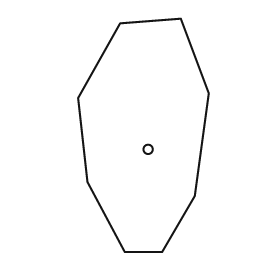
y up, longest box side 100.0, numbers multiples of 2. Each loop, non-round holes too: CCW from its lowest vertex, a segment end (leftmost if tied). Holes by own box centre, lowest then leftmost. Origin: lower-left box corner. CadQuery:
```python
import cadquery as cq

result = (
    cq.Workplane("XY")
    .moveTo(20.0, 0.0)
    .lineTo(36.0, 0.0)
    .lineTo(50.0, 24.0)
    .lineTo(56.0, 68.0)
    .lineTo(44.0, 100.0)
    .lineTo(18.0, 98.0)
    .lineTo(0.0, 66.0)
    .lineTo(4.0, 30.0)
    .close()
    .moveTo(30.0, 44.0)
    .circle(2.0)
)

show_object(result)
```